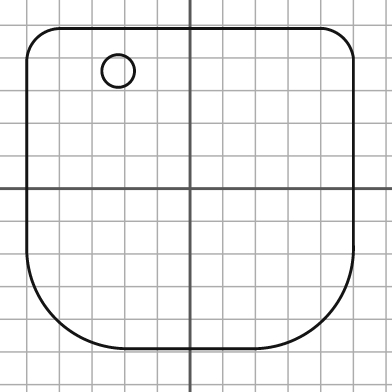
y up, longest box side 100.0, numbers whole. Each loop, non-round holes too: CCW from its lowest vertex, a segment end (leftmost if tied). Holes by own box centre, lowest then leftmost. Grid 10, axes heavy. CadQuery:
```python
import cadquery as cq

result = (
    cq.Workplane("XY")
    .moveTo(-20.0, -49.0)
    .lineTo(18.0, -49.0)
    .threePointArc((41.0, -40.0), (50.0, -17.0))
    .lineTo(50.0, 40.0)
    .threePointArc((47.0, 46.0), (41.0, 49.0))
    .lineTo(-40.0, 49.0)
    .threePointArc((-47.0, 46.0), (-50.0, 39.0))
    .lineTo(-50.0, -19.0)
    .threePointArc((-41.0, -40.0), (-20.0, -49.0))
    .close()
    .moveTo(-22.0, 36.0)
    .circle(5.0)
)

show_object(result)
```